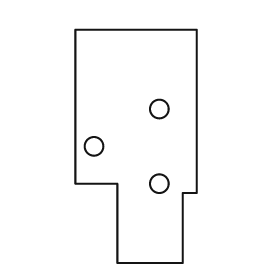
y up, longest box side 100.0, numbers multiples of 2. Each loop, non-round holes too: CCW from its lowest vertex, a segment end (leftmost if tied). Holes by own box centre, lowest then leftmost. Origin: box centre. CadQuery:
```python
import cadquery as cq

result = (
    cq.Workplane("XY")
    .moveTo(-8.0, -50.0)
    .lineTo(20.0, -50.0)
    .lineTo(20.0, -20.0)
    .lineTo(26.0, -20.0)
    .lineTo(26.0, 50.0)
    .lineTo(-26.0, 50.0)
    .lineTo(-26.0, -16.0)
    .lineTo(-8.0, -16.0)
    .close()
    .moveTo(10.0, -16.0)
    .circle(4.0)
    .moveTo(-18.0, 0.0)
    .circle(4.0)
    .moveTo(10.0, 16.0)
    .circle(4.0)
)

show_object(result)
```